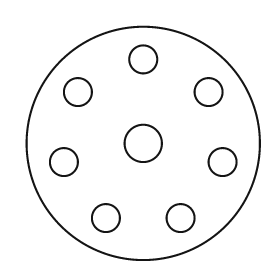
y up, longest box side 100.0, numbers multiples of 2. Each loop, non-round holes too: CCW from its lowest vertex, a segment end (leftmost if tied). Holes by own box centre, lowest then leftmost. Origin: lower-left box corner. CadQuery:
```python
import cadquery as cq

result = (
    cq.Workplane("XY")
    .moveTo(50.0, 50.0)
    .circle(50.0)
    .moveTo(34.0, 18.0)
    .circle(6.0)
    .moveTo(66.0, 18.0)
    .circle(6.0)
    .moveTo(16.0, 42.0)
    .circle(6.0)
    .moveTo(84.0, 42.0)
    .circle(6.0)
    .moveTo(50.0, 50.0)
    .circle(8.0)
    .moveTo(22.0, 72.0)
    .circle(6.0)
    .moveTo(78.0, 72.0)
    .circle(6.0)
    .moveTo(50.0, 86.0)
    .circle(6.0)
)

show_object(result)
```